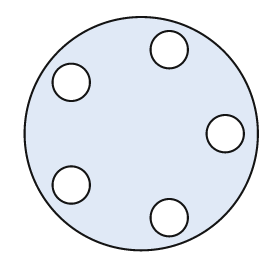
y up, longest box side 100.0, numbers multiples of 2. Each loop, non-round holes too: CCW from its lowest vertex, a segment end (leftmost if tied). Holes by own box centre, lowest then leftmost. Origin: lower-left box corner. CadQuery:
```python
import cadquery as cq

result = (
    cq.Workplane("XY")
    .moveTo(50.0, 50.0)
    .circle(50.0)
    .moveTo(62.0, 14.0)
    .circle(8.0)
    .moveTo(20.0, 28.0)
    .circle(8.0)
    .moveTo(86.0, 50.0)
    .circle(8.0)
    .moveTo(20.0, 72.0)
    .circle(8.0)
    .moveTo(62.0, 86.0)
    .circle(8.0)
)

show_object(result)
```